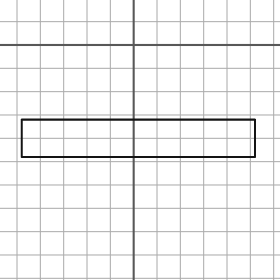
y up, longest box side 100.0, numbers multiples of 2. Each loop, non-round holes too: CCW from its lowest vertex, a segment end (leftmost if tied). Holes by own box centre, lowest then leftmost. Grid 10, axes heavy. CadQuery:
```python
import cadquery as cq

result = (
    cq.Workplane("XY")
    .moveTo(-48.0, -48.0)
    .lineTo(52.0, -48.0)
    .lineTo(52.0, -32.0)
    .lineTo(-48.0, -32.0)
    .close()
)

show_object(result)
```